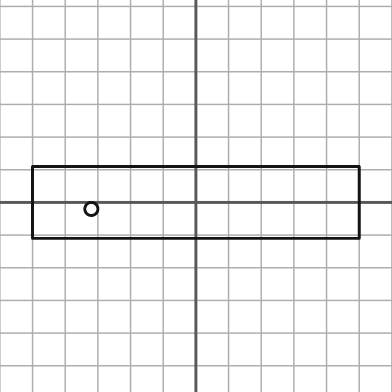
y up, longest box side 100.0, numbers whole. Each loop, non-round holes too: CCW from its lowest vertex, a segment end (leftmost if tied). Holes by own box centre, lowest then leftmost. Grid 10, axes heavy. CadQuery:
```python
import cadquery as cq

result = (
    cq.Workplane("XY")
    .moveTo(-50.0, -11.0)
    .lineTo(50.0, -11.0)
    .lineTo(50.0, 11.0)
    .lineTo(-50.0, 11.0)
    .close()
    .moveTo(-32.0, -2.0)
    .circle(2.0)
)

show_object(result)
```